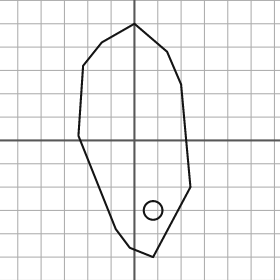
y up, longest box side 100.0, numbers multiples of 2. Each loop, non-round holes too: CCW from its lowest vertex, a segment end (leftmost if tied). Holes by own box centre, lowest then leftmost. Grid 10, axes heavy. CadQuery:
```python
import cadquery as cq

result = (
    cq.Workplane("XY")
    .moveTo(8.0, -50.0)
    .lineTo(24.0, -20.0)
    .lineTo(20.0, 24.0)
    .lineTo(14.0, 38.0)
    .lineTo(0.0, 50.0)
    .lineTo(-14.0, 42.0)
    .lineTo(-22.0, 32.0)
    .lineTo(-24.0, 2.0)
    .lineTo(-8.0, -38.0)
    .lineTo(-2.0, -46.0)
    .close()
    .moveTo(8.0, -30.0)
    .circle(4.0)
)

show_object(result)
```